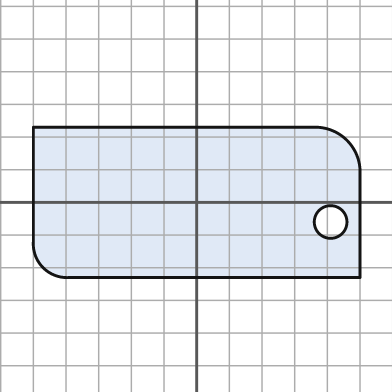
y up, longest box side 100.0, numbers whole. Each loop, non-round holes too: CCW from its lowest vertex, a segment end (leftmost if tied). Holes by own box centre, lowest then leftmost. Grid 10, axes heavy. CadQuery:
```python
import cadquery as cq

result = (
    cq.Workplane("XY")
    .moveTo(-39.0, -23.0)
    .lineTo(50.0, -23.0)
    .lineTo(50.0, 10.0)
    .threePointArc((46.0, 19.0), (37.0, 23.0))
    .lineTo(-50.0, 23.0)
    .lineTo(-50.0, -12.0)
    .threePointArc((-47.0, -20.0), (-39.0, -23.0))
    .close()
    .moveTo(41.0, -6.0)
    .circle(5.0)
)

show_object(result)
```